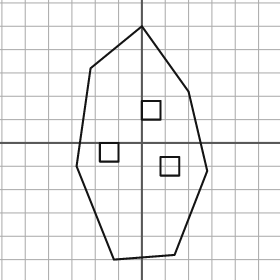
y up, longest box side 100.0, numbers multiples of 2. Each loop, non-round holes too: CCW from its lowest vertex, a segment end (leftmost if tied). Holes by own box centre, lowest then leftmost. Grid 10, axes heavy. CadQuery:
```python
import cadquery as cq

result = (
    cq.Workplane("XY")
    .moveTo(-12.0, -50.0)
    .lineTo(14.0, -48.0)
    .lineTo(28.0, -12.0)
    .lineTo(20.0, 22.0)
    .lineTo(0.0, 50.0)
    .lineTo(-22.0, 32.0)
    .lineTo(-28.0, -10.0)
    .close()
    .moveTo(8.0, -14.0)
    .lineTo(16.0, -14.0)
    .lineTo(16.0, -6.0)
    .lineTo(8.0, -6.0)
    .close()
    .moveTo(-18.0, -8.0)
    .lineTo(-10.0, -8.0)
    .lineTo(-10.0, 0.0)
    .lineTo(-18.0, 0.0)
    .close()
    .moveTo(0.0, 10.0)
    .lineTo(8.0, 10.0)
    .lineTo(8.0, 18.0)
    .lineTo(0.0, 18.0)
    .close()
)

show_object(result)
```